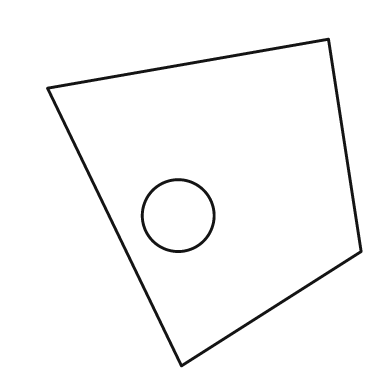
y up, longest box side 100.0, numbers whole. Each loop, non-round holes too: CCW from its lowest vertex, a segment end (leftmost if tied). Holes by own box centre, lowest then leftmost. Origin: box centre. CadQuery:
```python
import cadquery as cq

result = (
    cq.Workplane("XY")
    .moveTo(-7.0, -50.0)
    .lineTo(48.0, -15.0)
    .lineTo(38.0, 50.0)
    .lineTo(-48.0, 35.0)
    .close()
    .moveTo(-8.0, -4.0)
    .circle(11.0)
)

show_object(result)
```